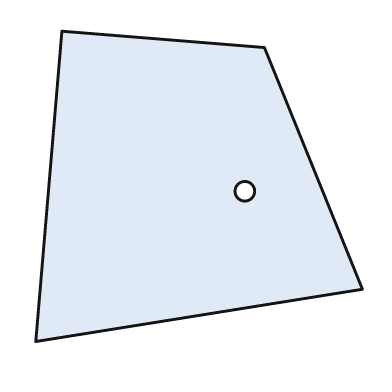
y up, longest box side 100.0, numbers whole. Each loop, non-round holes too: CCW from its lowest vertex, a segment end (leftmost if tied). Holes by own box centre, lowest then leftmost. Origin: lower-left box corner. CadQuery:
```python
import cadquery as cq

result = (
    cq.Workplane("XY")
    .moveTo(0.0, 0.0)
    .lineTo(100.0, 16.0)
    .lineTo(70.0, 90.0)
    .lineTo(8.0, 95.0)
    .close()
    .moveTo(64.0, 46.0)
    .circle(3.0)
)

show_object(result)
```